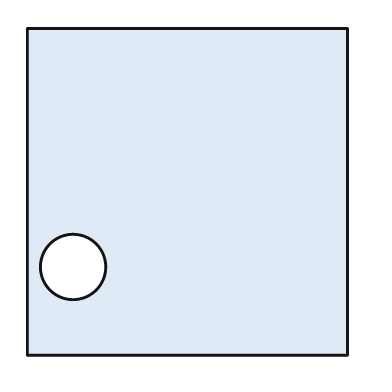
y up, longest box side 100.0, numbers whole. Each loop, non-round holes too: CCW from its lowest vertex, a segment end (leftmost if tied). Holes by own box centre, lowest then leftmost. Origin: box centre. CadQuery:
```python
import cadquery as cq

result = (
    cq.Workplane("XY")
    .moveTo(-49.0, -50.0)
    .lineTo(49.0, -50.0)
    .lineTo(49.0, 50.0)
    .lineTo(-49.0, 50.0)
    .close()
    .moveTo(-35.0, -23.0)
    .circle(10.0)
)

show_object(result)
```